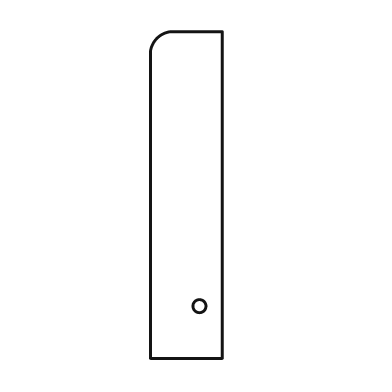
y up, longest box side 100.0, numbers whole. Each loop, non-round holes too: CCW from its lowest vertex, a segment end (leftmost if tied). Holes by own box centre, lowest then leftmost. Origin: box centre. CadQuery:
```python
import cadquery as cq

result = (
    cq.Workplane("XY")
    .moveTo(-11.0, -50.0)
    .lineTo(11.0, -50.0)
    .lineTo(11.0, 50.0)
    .lineTo(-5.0, 50.0)
    .threePointArc((-9.0, 48.0), (-11.0, 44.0))
    .close()
    .moveTo(4.0, -34.0)
    .circle(2.0)
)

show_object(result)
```